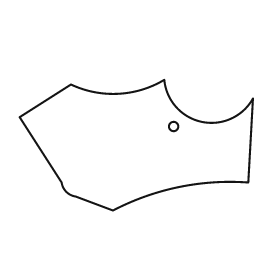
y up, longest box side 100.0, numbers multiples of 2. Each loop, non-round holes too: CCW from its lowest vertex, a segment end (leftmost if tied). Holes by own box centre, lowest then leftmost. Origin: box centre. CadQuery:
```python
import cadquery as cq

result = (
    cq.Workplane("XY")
    .moveTo(-10.0, -28.0)
    .threePointArc((18.0, -18.0), (48.0, -16.0))
    .lineTo(50.0, 20.0)
    .threePointArc((28.0, 10.0), (12.0, 28.0))
    .threePointArc((-8.0, 22.0), (-28.0, 26.0))
    .lineTo(-50.0, 12.0)
    .lineTo(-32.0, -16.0)
    .threePointArc((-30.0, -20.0), (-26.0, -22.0))
    .close()
    .moveTo(16.0, 8.0)
    .circle(2.0)
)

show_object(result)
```